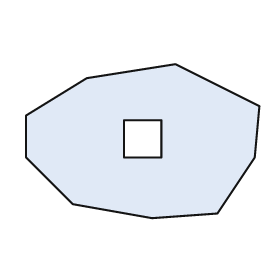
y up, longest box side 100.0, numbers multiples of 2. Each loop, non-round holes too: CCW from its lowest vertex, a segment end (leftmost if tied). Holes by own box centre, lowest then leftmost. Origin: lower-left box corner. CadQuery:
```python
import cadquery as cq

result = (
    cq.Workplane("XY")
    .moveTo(54.0, 0.0)
    .lineTo(82.0, 2.0)
    .lineTo(98.0, 26.0)
    .lineTo(100.0, 48.0)
    .lineTo(64.0, 66.0)
    .lineTo(26.0, 60.0)
    .lineTo(0.0, 44.0)
    .lineTo(0.0, 26.0)
    .lineTo(20.0, 6.0)
    .close()
    .moveTo(42.0, 26.0)
    .lineTo(58.0, 26.0)
    .lineTo(58.0, 42.0)
    .lineTo(42.0, 42.0)
    .close()
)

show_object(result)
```